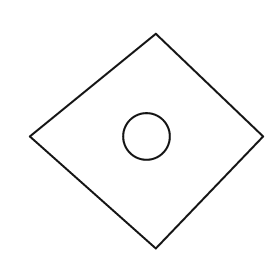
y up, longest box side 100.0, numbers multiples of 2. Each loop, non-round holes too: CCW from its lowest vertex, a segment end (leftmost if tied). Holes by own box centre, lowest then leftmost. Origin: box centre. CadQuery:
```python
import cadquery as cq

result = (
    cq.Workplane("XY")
    .moveTo(4.0, -46.0)
    .lineTo(50.0, 2.0)
    .lineTo(4.0, 46.0)
    .lineTo(-50.0, 2.0)
    .close()
    .moveTo(0.0, 2.0)
    .circle(10.0)
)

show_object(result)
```